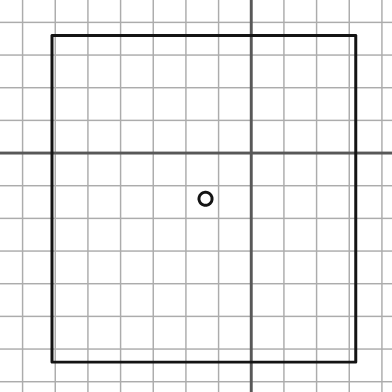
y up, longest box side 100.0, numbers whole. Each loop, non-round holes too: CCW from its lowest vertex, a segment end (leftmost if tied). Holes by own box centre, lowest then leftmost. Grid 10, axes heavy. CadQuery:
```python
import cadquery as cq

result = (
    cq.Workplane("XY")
    .moveTo(-61.0, -64.0)
    .lineTo(32.0, -64.0)
    .lineTo(32.0, 36.0)
    .lineTo(-61.0, 36.0)
    .close()
    .moveTo(-14.0, -14.0)
    .circle(2.0)
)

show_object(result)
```